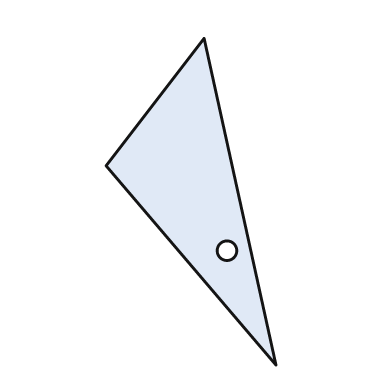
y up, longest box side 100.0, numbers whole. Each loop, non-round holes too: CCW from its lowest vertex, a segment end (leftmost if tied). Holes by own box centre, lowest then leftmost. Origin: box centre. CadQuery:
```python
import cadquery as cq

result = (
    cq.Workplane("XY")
    .moveTo(26.0, -50.0)
    .lineTo(4.0, 50.0)
    .lineTo(-26.0, 11.0)
    .close()
    .moveTo(11.0, -15.0)
    .circle(3.0)
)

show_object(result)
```